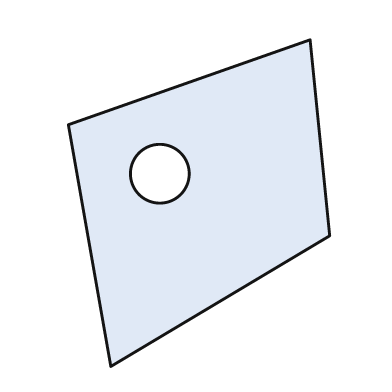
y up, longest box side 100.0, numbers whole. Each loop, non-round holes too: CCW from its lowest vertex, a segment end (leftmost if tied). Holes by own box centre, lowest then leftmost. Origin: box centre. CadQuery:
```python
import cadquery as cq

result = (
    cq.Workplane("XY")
    .moveTo(-27.0, -50.0)
    .lineTo(40.0, -10.0)
    .lineTo(34.0, 50.0)
    .lineTo(-40.0, 24.0)
    .close()
    .moveTo(-12.0, 9.0)
    .circle(9.0)
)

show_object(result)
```